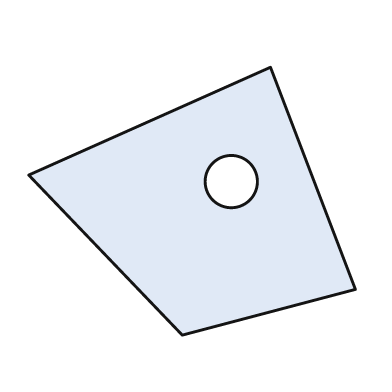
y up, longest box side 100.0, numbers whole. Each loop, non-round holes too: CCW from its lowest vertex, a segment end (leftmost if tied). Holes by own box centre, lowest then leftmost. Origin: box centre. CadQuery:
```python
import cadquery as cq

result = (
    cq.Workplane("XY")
    .moveTo(-3.0, -41.0)
    .lineTo(50.0, -27.0)
    .lineTo(24.0, 41.0)
    .lineTo(-50.0, 8.0)
    .close()
    .moveTo(12.0, 6.0)
    .circle(8.0)
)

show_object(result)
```